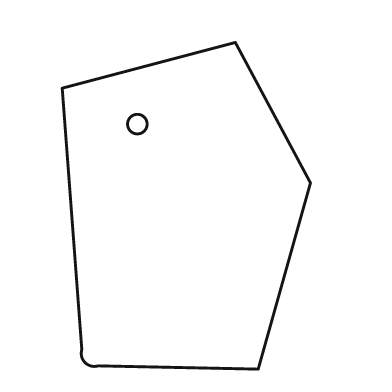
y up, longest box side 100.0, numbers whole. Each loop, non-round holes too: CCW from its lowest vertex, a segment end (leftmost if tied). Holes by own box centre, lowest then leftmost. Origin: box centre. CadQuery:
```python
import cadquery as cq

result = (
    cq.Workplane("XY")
    .moveTo(22.0, -50.0)
    .lineTo(38.0, 7.0)
    .lineTo(15.0, 50.0)
    .lineTo(-38.0, 36.0)
    .lineTo(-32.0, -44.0)
    .threePointArc((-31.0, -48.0), (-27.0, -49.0))
    .close()
    .moveTo(-15.0, 25.0)
    .circle(3.0)
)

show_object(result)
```